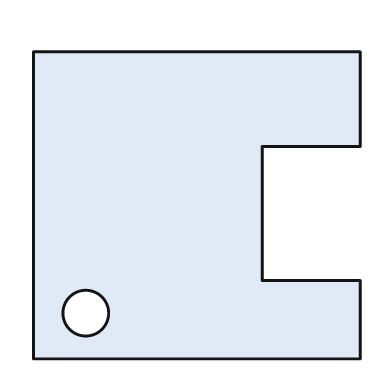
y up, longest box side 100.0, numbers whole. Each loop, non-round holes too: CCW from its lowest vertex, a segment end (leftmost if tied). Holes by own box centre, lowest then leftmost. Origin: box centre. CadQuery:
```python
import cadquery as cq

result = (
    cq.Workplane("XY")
    .moveTo(-50.0, -47.0)
    .lineTo(50.0, -47.0)
    .lineTo(50.0, -23.0)
    .lineTo(20.0, -23.0)
    .lineTo(20.0, 18.0)
    .lineTo(50.0, 18.0)
    .lineTo(50.0, 47.0)
    .lineTo(-50.0, 47.0)
    .close()
    .moveTo(-34.0, -33.0)
    .circle(7.0)
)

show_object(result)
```